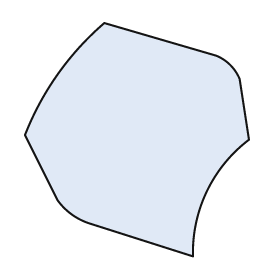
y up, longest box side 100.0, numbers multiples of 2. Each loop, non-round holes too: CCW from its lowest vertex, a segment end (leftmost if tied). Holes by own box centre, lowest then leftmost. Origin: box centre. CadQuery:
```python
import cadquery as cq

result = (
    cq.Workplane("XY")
    .moveTo(24.0, -50.0)
    .threePointArc((30.0, -22.0), (48.0, 0.0))
    .lineTo(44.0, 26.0)
    .threePointArc((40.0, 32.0), (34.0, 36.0))
    .lineTo(-14.0, 50.0)
    .threePointArc((-34.0, 28.0), (-48.0, 2.0))
    .lineTo(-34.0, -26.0)
    .threePointArc((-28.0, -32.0), (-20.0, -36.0))
    .close()
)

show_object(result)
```